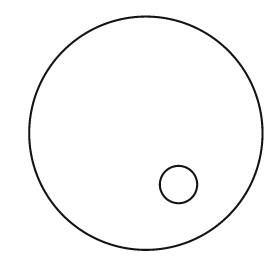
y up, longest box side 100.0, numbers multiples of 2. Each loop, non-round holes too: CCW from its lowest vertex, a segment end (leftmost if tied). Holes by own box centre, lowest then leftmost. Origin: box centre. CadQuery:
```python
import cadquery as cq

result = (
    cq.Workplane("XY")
    .moveTo(0.0, 0.0)
    .circle(50.0)
    .moveTo(14.0, -22.0)
    .circle(8.0)
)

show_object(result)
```